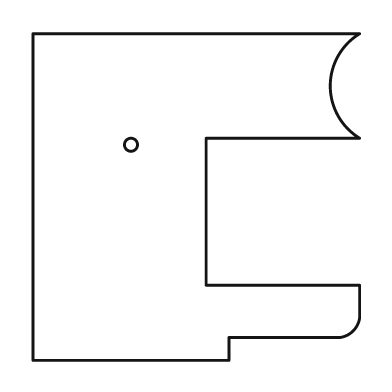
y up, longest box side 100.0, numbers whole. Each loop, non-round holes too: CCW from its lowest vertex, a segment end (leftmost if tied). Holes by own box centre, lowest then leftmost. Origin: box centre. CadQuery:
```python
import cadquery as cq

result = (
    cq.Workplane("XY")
    .moveTo(-50.0, -50.0)
    .lineTo(10.0, -50.0)
    .lineTo(10.0, -43.0)
    .lineTo(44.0, -43.0)
    .threePointArc((48.0, -41.0), (50.0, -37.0))
    .lineTo(50.0, -27.0)
    .lineTo(3.0, -27.0)
    .lineTo(3.0, 18.0)
    .lineTo(50.0, 18.0)
    .threePointArc((41.0, 34.0), (50.0, 50.0))
    .lineTo(-50.0, 50.0)
    .close()
    .moveTo(-20.0, 16.0)
    .circle(2.0)
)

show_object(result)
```